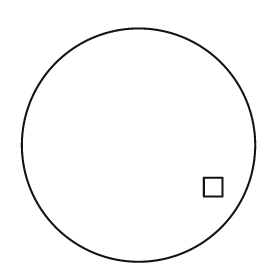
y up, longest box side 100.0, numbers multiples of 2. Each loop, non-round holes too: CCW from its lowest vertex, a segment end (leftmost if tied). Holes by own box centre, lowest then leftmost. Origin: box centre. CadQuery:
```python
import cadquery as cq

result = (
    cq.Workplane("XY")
    .moveTo(0.0, 0.0)
    .circle(50.0)
    .moveTo(28.0, -22.0)
    .lineTo(36.0, -22.0)
    .lineTo(36.0, -14.0)
    .lineTo(28.0, -14.0)
    .close()
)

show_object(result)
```